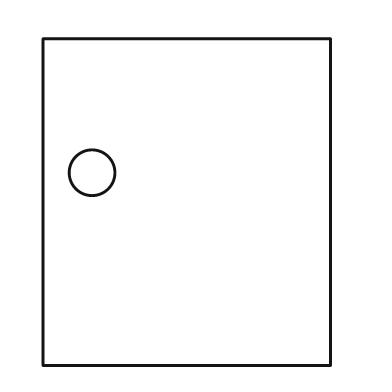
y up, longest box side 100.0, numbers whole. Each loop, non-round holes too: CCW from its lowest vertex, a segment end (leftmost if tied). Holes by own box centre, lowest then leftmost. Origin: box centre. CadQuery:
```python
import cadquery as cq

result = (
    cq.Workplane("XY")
    .moveTo(-44.0, -50.0)
    .lineTo(44.0, -50.0)
    .lineTo(44.0, 50.0)
    .lineTo(-44.0, 50.0)
    .close()
    .moveTo(-29.0, 9.0)
    .circle(7.0)
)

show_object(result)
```